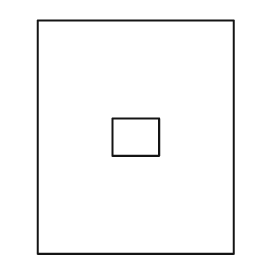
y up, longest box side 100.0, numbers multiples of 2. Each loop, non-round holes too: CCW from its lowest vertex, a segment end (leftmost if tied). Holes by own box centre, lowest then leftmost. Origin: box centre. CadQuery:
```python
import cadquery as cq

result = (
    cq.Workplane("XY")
    .moveTo(-42.0, -50.0)
    .lineTo(42.0, -50.0)
    .lineTo(42.0, 50.0)
    .lineTo(-42.0, 50.0)
    .close()
    .moveTo(-10.0, -8.0)
    .lineTo(10.0, -8.0)
    .lineTo(10.0, 8.0)
    .lineTo(-10.0, 8.0)
    .close()
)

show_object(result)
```